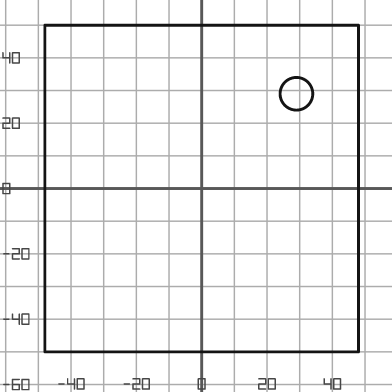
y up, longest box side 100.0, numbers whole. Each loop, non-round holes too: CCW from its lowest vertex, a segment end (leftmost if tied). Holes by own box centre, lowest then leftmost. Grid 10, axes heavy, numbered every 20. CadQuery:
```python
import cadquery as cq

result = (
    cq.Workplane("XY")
    .moveTo(-48.0, -50.0)
    .lineTo(48.0, -50.0)
    .lineTo(48.0, 50.0)
    .lineTo(-48.0, 50.0)
    .close()
    .moveTo(29.0, 29.0)
    .circle(5.0)
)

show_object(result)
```